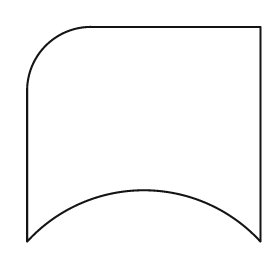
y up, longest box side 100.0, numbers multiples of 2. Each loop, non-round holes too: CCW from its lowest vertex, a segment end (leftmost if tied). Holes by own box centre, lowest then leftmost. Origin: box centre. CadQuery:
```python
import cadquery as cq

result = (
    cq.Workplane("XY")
    .moveTo(-50.0, -46.0)
    .threePointArc((0.0, -24.0), (50.0, -46.0))
    .lineTo(50.0, 46.0)
    .lineTo(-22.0, 46.0)
    .threePointArc((-42.0, 38.0), (-50.0, 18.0))
    .close()
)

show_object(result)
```